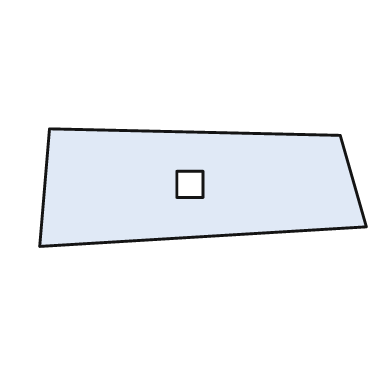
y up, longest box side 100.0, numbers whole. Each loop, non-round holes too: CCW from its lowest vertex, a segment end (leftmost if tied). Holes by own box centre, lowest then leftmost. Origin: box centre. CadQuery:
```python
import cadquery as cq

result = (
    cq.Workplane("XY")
    .moveTo(-50.0, -18.0)
    .lineTo(50.0, -12.0)
    .lineTo(42.0, 16.0)
    .lineTo(-47.0, 18.0)
    .close()
    .moveTo(-8.0, -3.0)
    .lineTo(0.0, -3.0)
    .lineTo(0.0, 5.0)
    .lineTo(-8.0, 5.0)
    .close()
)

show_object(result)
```